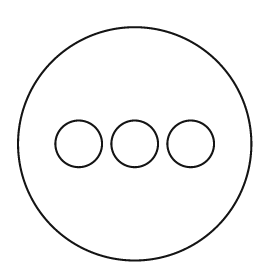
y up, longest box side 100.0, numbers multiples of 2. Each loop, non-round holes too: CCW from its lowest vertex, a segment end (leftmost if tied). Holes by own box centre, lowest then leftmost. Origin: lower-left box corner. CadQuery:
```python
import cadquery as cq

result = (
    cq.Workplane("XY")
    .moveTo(50.0, 50.0)
    .circle(50.0)
    .moveTo(26.0, 50.0)
    .circle(10.0)
    .moveTo(50.0, 50.0)
    .circle(10.0)
    .moveTo(74.0, 50.0)
    .circle(10.0)
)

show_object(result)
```